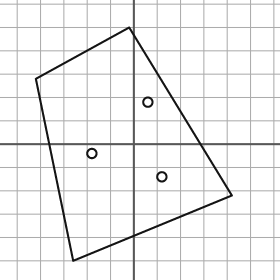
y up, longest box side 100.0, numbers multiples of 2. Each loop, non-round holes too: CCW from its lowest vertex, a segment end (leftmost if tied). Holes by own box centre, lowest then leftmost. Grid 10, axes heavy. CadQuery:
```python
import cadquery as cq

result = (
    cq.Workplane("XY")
    .moveTo(-26.0, -50.0)
    .lineTo(42.0, -22.0)
    .lineTo(-2.0, 50.0)
    .lineTo(-42.0, 28.0)
    .close()
    .moveTo(12.0, -14.0)
    .circle(2.0)
    .moveTo(-18.0, -4.0)
    .circle(2.0)
    .moveTo(6.0, 18.0)
    .circle(2.0)
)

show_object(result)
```